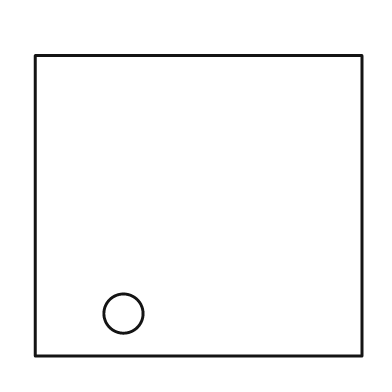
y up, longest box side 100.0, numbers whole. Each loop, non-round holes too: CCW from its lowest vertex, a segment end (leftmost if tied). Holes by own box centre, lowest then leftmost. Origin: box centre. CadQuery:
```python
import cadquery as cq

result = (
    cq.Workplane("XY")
    .moveTo(-50.0, -46.0)
    .lineTo(50.0, -46.0)
    .lineTo(50.0, 46.0)
    .lineTo(-50.0, 46.0)
    .close()
    .moveTo(-23.0, -33.0)
    .circle(6.0)
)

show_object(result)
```